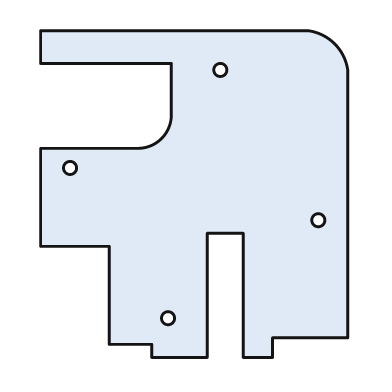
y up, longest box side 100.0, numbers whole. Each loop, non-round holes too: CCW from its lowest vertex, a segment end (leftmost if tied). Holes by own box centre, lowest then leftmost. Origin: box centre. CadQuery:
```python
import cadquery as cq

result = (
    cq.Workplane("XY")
    .moveTo(-13.0, -50.0)
    .lineTo(4.0, -50.0)
    .lineTo(4.0, -12.0)
    .lineTo(15.0, -12.0)
    .lineTo(15.0, -50.0)
    .lineTo(24.0, -50.0)
    .lineTo(24.0, -44.0)
    .lineTo(47.0, -44.0)
    .lineTo(47.0, 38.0)
    .threePointArc((43.0, 46.0), (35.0, 50.0))
    .lineTo(-47.0, 50.0)
    .lineTo(-47.0, 40.0)
    .lineTo(-7.0, 40.0)
    .lineTo(-7.0, 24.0)
    .threePointArc((-10.0, 17.0), (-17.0, 14.0))
    .lineTo(-47.0, 14.0)
    .lineTo(-47.0, -16.0)
    .lineTo(-26.0, -16.0)
    .lineTo(-26.0, -46.0)
    .lineTo(-13.0, -46.0)
    .close()
    .moveTo(-8.0, -38.0)
    .circle(2.0)
    .moveTo(38.0, -8.0)
    .circle(2.0)
    .moveTo(-38.0, 8.0)
    .circle(2.0)
    .moveTo(8.0, 38.0)
    .circle(2.0)
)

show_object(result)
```